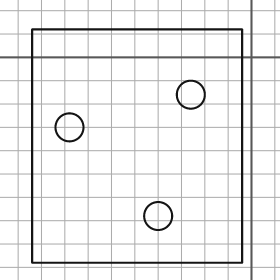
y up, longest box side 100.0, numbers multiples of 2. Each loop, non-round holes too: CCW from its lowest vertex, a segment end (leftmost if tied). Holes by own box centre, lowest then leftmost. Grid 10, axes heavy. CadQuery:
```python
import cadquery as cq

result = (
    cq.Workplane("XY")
    .moveTo(-94.0, -88.0)
    .lineTo(-4.0, -88.0)
    .lineTo(-4.0, 12.0)
    .lineTo(-94.0, 12.0)
    .close()
    .moveTo(-40.0, -68.0)
    .circle(6.0)
    .moveTo(-78.0, -30.0)
    .circle(6.0)
    .moveTo(-26.0, -16.0)
    .circle(6.0)
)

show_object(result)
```